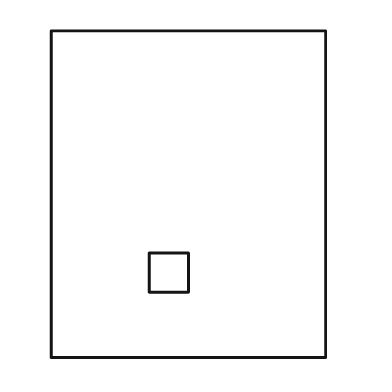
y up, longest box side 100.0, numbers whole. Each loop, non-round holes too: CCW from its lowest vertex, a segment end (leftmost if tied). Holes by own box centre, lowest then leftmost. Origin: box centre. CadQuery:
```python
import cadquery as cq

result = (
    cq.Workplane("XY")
    .moveTo(-42.0, -50.0)
    .lineTo(42.0, -50.0)
    .lineTo(42.0, 50.0)
    .lineTo(-42.0, 50.0)
    .close()
    .moveTo(-12.0, -30.0)
    .lineTo(0.0, -30.0)
    .lineTo(0.0, -18.0)
    .lineTo(-12.0, -18.0)
    .close()
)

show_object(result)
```